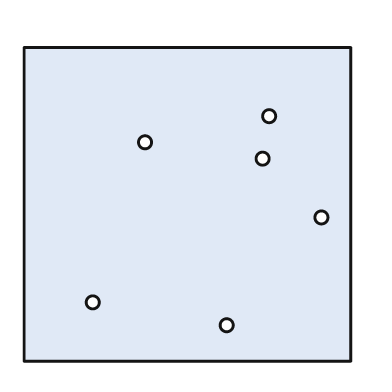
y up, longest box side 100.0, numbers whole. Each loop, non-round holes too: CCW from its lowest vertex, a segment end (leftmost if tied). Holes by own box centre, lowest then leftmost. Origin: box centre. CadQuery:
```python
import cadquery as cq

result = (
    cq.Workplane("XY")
    .moveTo(-50.0, -48.0)
    .lineTo(50.0, -48.0)
    .lineTo(50.0, 48.0)
    .lineTo(-50.0, 48.0)
    .close()
    .moveTo(12.0, -37.0)
    .circle(2.0)
    .moveTo(-29.0, -30.0)
    .circle(2.0)
    .moveTo(41.0, -4.0)
    .circle(2.0)
    .moveTo(23.0, 14.0)
    .circle(2.0)
    .moveTo(-13.0, 19.0)
    .circle(2.0)
    .moveTo(25.0, 27.0)
    .circle(2.0)
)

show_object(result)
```